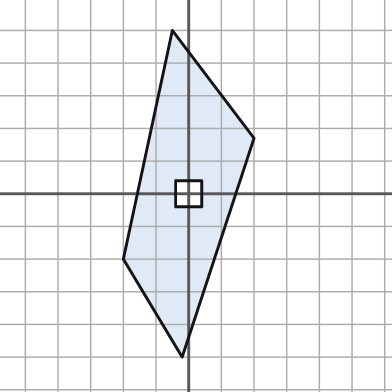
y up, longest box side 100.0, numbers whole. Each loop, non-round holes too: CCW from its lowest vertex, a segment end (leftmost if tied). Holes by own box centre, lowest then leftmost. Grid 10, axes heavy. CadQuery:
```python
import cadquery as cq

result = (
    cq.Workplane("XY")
    .moveTo(-2.0, -50.0)
    .lineTo(20.0, 17.0)
    .lineTo(-5.0, 50.0)
    .lineTo(-20.0, -20.0)
    .close()
    .moveTo(-4.0, -4.0)
    .lineTo(4.0, -4.0)
    .lineTo(4.0, 4.0)
    .lineTo(-4.0, 4.0)
    .close()
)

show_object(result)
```